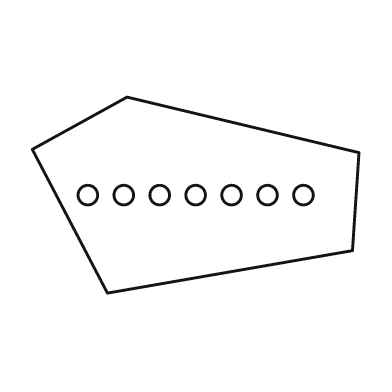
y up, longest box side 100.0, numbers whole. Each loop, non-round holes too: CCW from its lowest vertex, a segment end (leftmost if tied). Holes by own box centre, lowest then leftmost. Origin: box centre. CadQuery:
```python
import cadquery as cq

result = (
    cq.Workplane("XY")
    .moveTo(-27.0, -30.0)
    .lineTo(48.0, -17.0)
    .lineTo(50.0, 13.0)
    .lineTo(-21.0, 30.0)
    .lineTo(-50.0, 14.0)
    .close()
    .moveTo(-33.0, 0.0)
    .circle(3.0)
    .moveTo(-22.0, 0.0)
    .circle(3.0)
    .moveTo(-11.0, 0.0)
    .circle(3.0)
    .moveTo(0.0, 0.0)
    .circle(3.0)
    .moveTo(11.0, 0.0)
    .circle(3.0)
    .moveTo(22.0, 0.0)
    .circle(3.0)
    .moveTo(33.0, 0.0)
    .circle(3.0)
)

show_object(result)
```